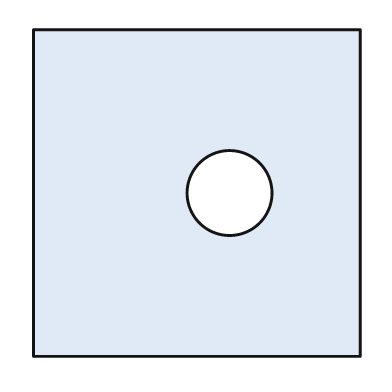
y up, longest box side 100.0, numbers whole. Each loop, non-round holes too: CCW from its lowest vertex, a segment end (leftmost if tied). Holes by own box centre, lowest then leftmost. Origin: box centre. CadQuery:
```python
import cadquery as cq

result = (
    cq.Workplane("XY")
    .moveTo(-50.0, -50.0)
    .lineTo(50.0, -50.0)
    .lineTo(50.0, 50.0)
    .lineTo(-50.0, 50.0)
    .close()
    .moveTo(10.0, 0.0)
    .circle(13.0)
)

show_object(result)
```